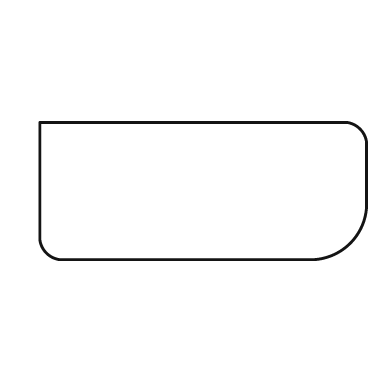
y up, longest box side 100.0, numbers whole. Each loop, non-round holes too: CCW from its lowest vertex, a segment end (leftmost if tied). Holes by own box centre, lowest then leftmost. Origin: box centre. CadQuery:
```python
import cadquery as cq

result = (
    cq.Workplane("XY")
    .moveTo(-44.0, -21.0)
    .lineTo(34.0, -21.0)
    .threePointArc((45.0, -16.0), (50.0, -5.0))
    .lineTo(50.0, 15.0)
    .threePointArc((48.0, 19.0), (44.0, 21.0))
    .lineTo(-50.0, 21.0)
    .lineTo(-50.0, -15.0)
    .threePointArc((-48.0, -19.0), (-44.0, -21.0))
    .close()
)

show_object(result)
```